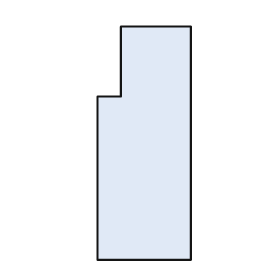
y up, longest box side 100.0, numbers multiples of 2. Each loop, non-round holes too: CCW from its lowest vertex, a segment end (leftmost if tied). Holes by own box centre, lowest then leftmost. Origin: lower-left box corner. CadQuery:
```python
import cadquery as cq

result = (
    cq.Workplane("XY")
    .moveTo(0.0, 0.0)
    .lineTo(40.0, 0.0)
    .lineTo(40.0, 100.0)
    .lineTo(10.0, 100.0)
    .lineTo(10.0, 70.0)
    .lineTo(0.0, 70.0)
    .close()
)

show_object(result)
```